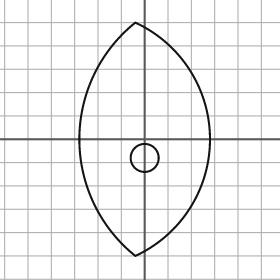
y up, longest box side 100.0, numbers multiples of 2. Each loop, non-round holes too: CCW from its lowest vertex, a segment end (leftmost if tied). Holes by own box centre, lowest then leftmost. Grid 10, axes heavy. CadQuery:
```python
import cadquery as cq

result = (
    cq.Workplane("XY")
    .moveTo(-4.0, -50.0)
    .threePointArc((28.0, 0.0), (-4.0, 50.0))
    .threePointArc((-28.0, 0.0), (-4.0, -50.0))
    .close()
    .moveTo(0.0, -8.0)
    .circle(6.0)
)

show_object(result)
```